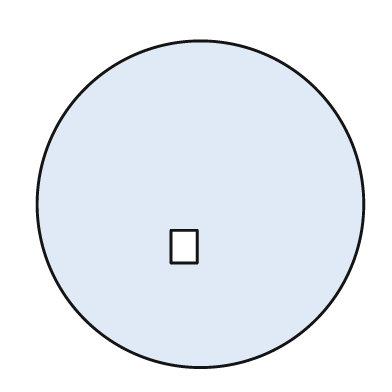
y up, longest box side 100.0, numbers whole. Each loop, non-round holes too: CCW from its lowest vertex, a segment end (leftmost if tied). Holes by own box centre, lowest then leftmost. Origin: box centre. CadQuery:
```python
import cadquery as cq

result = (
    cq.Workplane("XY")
    .moveTo(0.0, 0.0)
    .circle(50.0)
    .moveTo(-9.0, -18.0)
    .lineTo(-1.0, -18.0)
    .lineTo(-1.0, -8.0)
    .lineTo(-9.0, -8.0)
    .close()
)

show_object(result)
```